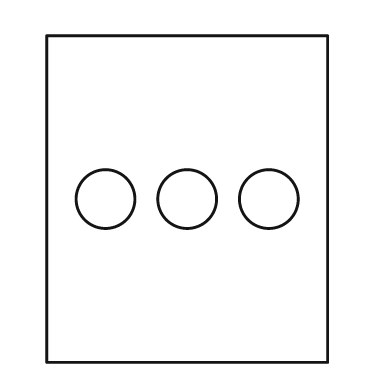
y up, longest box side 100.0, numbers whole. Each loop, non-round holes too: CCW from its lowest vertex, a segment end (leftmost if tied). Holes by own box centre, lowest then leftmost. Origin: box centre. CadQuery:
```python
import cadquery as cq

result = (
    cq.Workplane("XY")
    .moveTo(-43.0, -50.0)
    .lineTo(43.0, -50.0)
    .lineTo(43.0, 50.0)
    .lineTo(-43.0, 50.0)
    .close()
    .moveTo(-25.0, 0.0)
    .circle(9.0)
    .moveTo(0.0, 0.0)
    .circle(9.0)
    .moveTo(25.0, 0.0)
    .circle(9.0)
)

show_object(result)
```